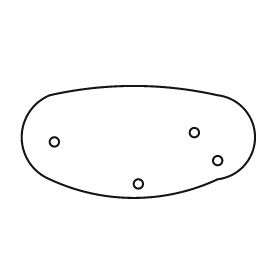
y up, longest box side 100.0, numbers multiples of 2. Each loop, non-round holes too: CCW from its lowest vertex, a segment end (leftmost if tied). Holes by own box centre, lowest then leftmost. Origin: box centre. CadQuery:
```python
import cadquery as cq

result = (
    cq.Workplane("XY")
    .moveTo(-38.0, -16.0)
    .threePointArc((-2.0, -24.0), (34.0, -16.0))
    .threePointArc((50.0, 2.0), (34.0, 20.0))
    .threePointArc((-2.0, 24.0), (-38.0, 20.0))
    .threePointArc((-50.0, 2.0), (-38.0, -16.0))
    .close()
    .moveTo(0.0, -18.0)
    .circle(2.0)
    .moveTo(34.0, -8.0)
    .circle(2.0)
    .moveTo(-36.0, 0.0)
    .circle(2.0)
    .moveTo(24.0, 4.0)
    .circle(2.0)
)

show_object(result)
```